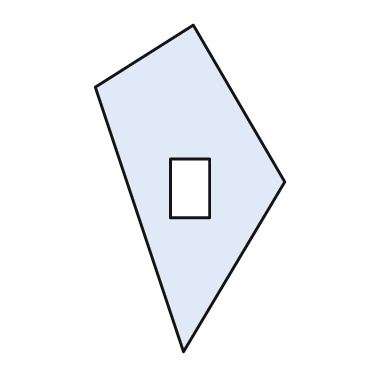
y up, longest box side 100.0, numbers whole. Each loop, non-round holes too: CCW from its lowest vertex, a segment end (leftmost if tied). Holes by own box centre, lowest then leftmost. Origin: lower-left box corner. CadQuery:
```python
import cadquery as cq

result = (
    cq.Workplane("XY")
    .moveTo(27.0, 0.0)
    .lineTo(58.0, 52.0)
    .lineTo(30.0, 100.0)
    .lineTo(0.0, 81.0)
    .close()
    .moveTo(23.0, 41.0)
    .lineTo(35.0, 41.0)
    .lineTo(35.0, 59.0)
    .lineTo(23.0, 59.0)
    .close()
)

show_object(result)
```